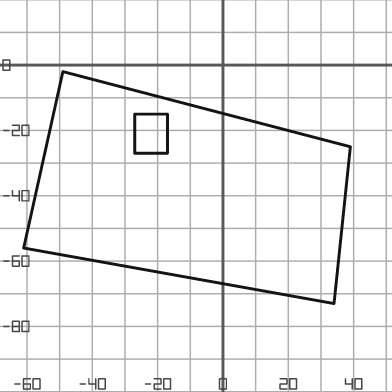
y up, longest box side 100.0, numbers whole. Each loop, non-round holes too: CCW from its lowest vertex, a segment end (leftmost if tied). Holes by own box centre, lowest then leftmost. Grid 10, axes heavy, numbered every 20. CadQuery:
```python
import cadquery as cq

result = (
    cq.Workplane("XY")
    .moveTo(34.0, -73.0)
    .lineTo(39.0, -25.0)
    .lineTo(-49.0, -2.0)
    .lineTo(-61.0, -56.0)
    .close()
    .moveTo(-27.0, -27.0)
    .lineTo(-17.0, -27.0)
    .lineTo(-17.0, -15.0)
    .lineTo(-27.0, -15.0)
    .close()
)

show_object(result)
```